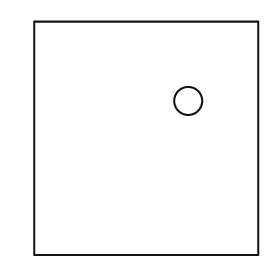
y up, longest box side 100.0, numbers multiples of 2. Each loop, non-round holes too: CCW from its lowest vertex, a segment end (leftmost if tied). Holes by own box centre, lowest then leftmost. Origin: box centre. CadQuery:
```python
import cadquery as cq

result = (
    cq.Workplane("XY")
    .moveTo(-48.0, -50.0)
    .lineTo(48.0, -50.0)
    .lineTo(48.0, 50.0)
    .lineTo(-48.0, 50.0)
    .close()
    .moveTo(18.0, 16.0)
    .circle(6.0)
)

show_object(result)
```